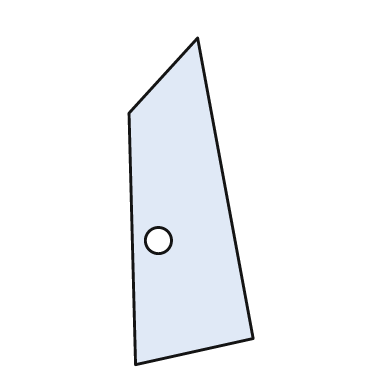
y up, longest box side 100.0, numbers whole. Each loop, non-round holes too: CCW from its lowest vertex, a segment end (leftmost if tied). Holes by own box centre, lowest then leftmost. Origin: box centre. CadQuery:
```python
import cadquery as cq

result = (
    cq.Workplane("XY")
    .moveTo(-17.0, -50.0)
    .lineTo(19.0, -42.0)
    .lineTo(2.0, 50.0)
    .lineTo(-19.0, 27.0)
    .close()
    .moveTo(-10.0, -12.0)
    .circle(4.0)
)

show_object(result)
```